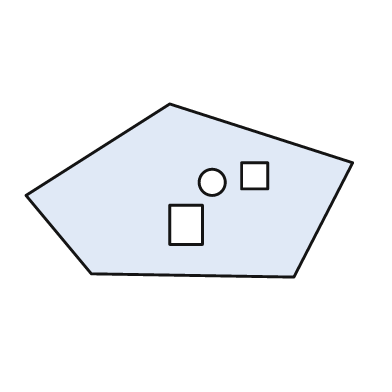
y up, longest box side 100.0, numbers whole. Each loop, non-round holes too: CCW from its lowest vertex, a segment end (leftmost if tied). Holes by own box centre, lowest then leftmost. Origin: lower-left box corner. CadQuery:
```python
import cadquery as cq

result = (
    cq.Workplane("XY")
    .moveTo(82.0, 0.0)
    .lineTo(100.0, 35.0)
    .lineTo(44.0, 53.0)
    .lineTo(0.0, 25.0)
    .lineTo(20.0, 1.0)
    .close()
    .moveTo(44.0, 10.0)
    .lineTo(54.0, 10.0)
    .lineTo(54.0, 22.0)
    .lineTo(44.0, 22.0)
    .close()
    .moveTo(57.0, 29.0)
    .circle(4.0)
    .moveTo(66.0, 27.0)
    .lineTo(74.0, 27.0)
    .lineTo(74.0, 35.0)
    .lineTo(66.0, 35.0)
    .close()
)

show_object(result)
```